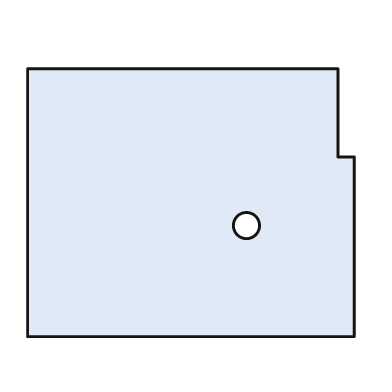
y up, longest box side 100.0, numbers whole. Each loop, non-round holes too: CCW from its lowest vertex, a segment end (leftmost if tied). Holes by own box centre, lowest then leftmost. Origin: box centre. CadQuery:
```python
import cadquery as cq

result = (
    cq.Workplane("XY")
    .moveTo(-50.0, -41.0)
    .lineTo(50.0, -41.0)
    .lineTo(50.0, 14.0)
    .lineTo(45.0, 14.0)
    .lineTo(45.0, 41.0)
    .lineTo(-50.0, 41.0)
    .close()
    .moveTo(17.0, -7.0)
    .circle(4.0)
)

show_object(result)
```